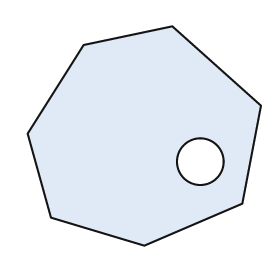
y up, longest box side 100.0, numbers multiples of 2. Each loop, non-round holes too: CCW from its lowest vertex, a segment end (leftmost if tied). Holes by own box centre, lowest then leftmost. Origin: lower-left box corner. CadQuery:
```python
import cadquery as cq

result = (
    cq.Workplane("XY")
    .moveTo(50.0, 0.0)
    .lineTo(92.0, 18.0)
    .lineTo(100.0, 60.0)
    .lineTo(62.0, 94.0)
    .lineTo(24.0, 86.0)
    .lineTo(0.0, 48.0)
    .lineTo(10.0, 12.0)
    .close()
    .moveTo(74.0, 36.0)
    .circle(10.0)
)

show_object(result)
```